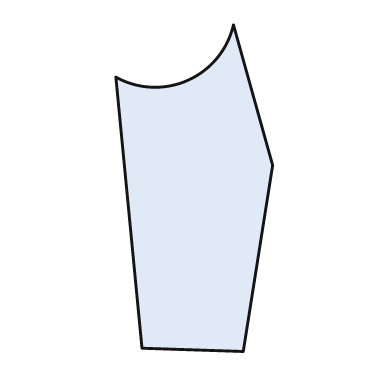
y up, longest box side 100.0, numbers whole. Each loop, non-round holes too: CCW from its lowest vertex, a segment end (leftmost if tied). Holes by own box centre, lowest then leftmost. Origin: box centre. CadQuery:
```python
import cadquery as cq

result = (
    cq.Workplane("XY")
    .moveTo(15.0, -50.0)
    .lineTo(24.0, 7.0)
    .lineTo(12.0, 50.0)
    .threePointArc((-2.0, 33.0), (-24.0, 34.0))
    .lineTo(-16.0, -49.0)
    .close()
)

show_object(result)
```